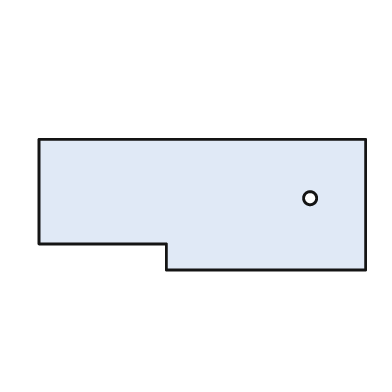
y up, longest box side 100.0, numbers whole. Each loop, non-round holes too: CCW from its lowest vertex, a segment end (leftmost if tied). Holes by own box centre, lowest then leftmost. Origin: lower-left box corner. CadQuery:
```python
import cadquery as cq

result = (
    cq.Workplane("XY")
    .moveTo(39.0, 0.0)
    .lineTo(100.0, 0.0)
    .lineTo(100.0, 40.0)
    .lineTo(0.0, 40.0)
    .lineTo(0.0, 8.0)
    .lineTo(39.0, 8.0)
    .close()
    .moveTo(83.0, 22.0)
    .circle(2.0)
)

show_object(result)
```